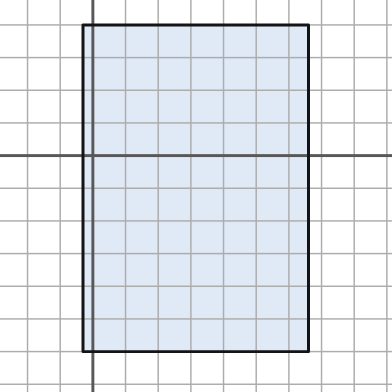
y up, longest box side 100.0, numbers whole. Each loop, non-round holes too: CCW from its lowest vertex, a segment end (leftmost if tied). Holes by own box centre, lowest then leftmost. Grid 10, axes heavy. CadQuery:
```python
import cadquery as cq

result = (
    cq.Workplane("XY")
    .moveTo(-3.0, -60.0)
    .lineTo(66.0, -60.0)
    .lineTo(66.0, 40.0)
    .lineTo(-3.0, 40.0)
    .close()
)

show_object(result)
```